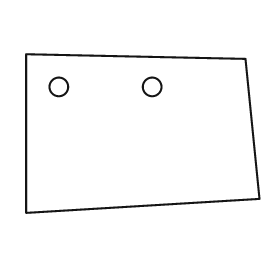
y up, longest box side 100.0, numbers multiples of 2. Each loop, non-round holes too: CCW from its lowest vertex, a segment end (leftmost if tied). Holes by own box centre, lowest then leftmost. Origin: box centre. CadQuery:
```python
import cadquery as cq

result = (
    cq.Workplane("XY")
    .moveTo(-50.0, -34.0)
    .lineTo(50.0, -28.0)
    .lineTo(44.0, 32.0)
    .lineTo(-50.0, 34.0)
    .close()
    .moveTo(-36.0, 20.0)
    .circle(4.0)
    .moveTo(4.0, 20.0)
    .circle(4.0)
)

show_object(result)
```